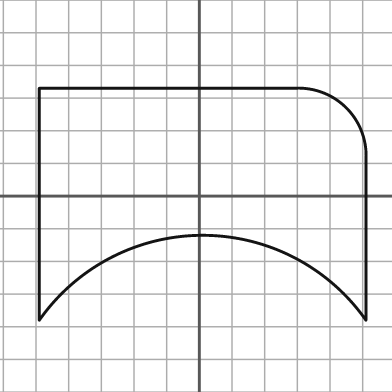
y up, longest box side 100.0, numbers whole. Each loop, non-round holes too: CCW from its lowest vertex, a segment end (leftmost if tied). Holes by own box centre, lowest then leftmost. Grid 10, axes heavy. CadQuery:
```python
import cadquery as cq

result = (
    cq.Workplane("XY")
    .moveTo(-49.0, -38.0)
    .threePointArc((1.0, -12.0), (51.0, -38.0))
    .lineTo(51.0, 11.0)
    .threePointArc((45.0, 27.0), (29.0, 33.0))
    .lineTo(-49.0, 33.0)
    .close()
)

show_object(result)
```